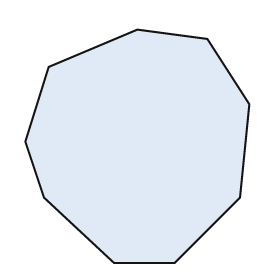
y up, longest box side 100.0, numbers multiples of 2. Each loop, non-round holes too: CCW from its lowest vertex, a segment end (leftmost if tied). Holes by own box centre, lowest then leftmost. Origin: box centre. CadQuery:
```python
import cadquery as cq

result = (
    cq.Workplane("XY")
    .moveTo(-10.0, -50.0)
    .lineTo(16.0, -50.0)
    .lineTo(44.0, -22.0)
    .lineTo(48.0, 18.0)
    .lineTo(30.0, 46.0)
    .lineTo(0.0, 50.0)
    .lineTo(-38.0, 34.0)
    .lineTo(-48.0, 2.0)
    .lineTo(-40.0, -22.0)
    .close()
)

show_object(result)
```